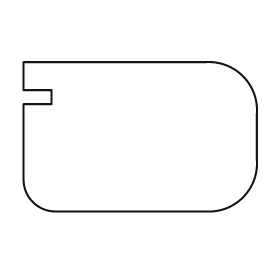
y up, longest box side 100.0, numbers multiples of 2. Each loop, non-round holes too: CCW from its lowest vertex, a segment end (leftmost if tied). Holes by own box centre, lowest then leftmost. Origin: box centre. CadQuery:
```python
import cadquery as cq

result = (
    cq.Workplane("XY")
    .moveTo(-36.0, -32.0)
    .lineTo(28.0, -32.0)
    .threePointArc((44.0, -26.0), (50.0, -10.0))
    .lineTo(50.0, 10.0)
    .threePointArc((44.0, 26.0), (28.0, 32.0))
    .lineTo(-50.0, 32.0)
    .lineTo(-50.0, 20.0)
    .lineTo(-38.0, 20.0)
    .lineTo(-38.0, 14.0)
    .lineTo(-50.0, 14.0)
    .lineTo(-50.0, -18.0)
    .threePointArc((-46.0, -28.0), (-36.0, -32.0))
    .close()
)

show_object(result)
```